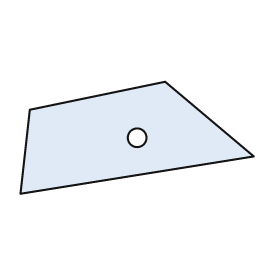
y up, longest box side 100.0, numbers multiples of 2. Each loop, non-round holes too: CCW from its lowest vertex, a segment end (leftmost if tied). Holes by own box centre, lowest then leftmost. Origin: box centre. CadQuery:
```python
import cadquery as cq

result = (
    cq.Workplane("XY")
    .moveTo(-50.0, -24.0)
    .lineTo(50.0, -8.0)
    .lineTo(12.0, 24.0)
    .lineTo(-46.0, 12.0)
    .close()
    .moveTo(0.0, 0.0)
    .circle(4.0)
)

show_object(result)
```